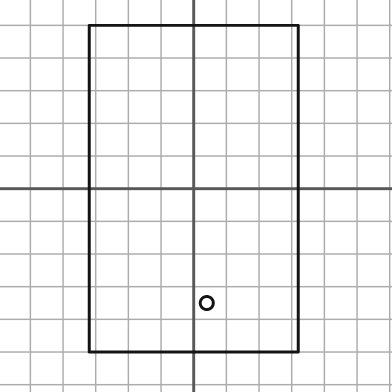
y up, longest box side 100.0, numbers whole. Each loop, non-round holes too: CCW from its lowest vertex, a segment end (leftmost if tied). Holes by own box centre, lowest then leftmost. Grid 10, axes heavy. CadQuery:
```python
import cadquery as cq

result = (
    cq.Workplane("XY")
    .moveTo(-32.0, -50.0)
    .lineTo(32.0, -50.0)
    .lineTo(32.0, 50.0)
    .lineTo(-32.0, 50.0)
    .close()
    .moveTo(4.0, -35.0)
    .circle(2.0)
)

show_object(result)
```